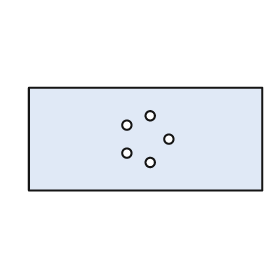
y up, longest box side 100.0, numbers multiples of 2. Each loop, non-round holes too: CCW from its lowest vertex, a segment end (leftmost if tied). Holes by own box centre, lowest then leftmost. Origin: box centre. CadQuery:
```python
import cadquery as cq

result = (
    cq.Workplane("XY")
    .moveTo(-50.0, -22.0)
    .lineTo(50.0, -22.0)
    .lineTo(50.0, 22.0)
    .lineTo(-50.0, 22.0)
    .close()
    .moveTo(2.0, -10.0)
    .circle(2.0)
    .moveTo(-8.0, -6.0)
    .circle(2.0)
    .moveTo(10.0, 0.0)
    .circle(2.0)
    .moveTo(-8.0, 6.0)
    .circle(2.0)
    .moveTo(2.0, 10.0)
    .circle(2.0)
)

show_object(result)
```